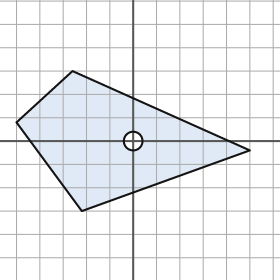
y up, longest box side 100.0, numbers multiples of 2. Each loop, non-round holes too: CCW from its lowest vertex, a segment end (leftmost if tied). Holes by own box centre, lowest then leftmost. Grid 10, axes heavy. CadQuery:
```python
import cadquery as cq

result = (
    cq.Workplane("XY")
    .moveTo(-22.0, -30.0)
    .lineTo(50.0, -4.0)
    .lineTo(-26.0, 30.0)
    .lineTo(-50.0, 8.0)
    .close()
    .moveTo(0.0, 0.0)
    .circle(4.0)
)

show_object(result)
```